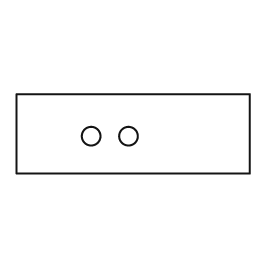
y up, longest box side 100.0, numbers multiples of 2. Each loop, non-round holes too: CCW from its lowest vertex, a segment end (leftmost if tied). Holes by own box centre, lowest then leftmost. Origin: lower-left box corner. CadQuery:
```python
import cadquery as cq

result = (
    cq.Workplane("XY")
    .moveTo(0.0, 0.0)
    .lineTo(100.0, 0.0)
    .lineTo(100.0, 34.0)
    .lineTo(0.0, 34.0)
    .close()
    .moveTo(32.0, 16.0)
    .circle(4.0)
    .moveTo(48.0, 16.0)
    .circle(4.0)
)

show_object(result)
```